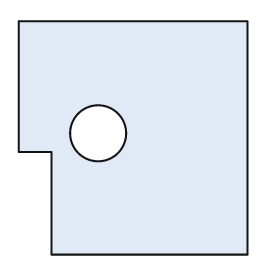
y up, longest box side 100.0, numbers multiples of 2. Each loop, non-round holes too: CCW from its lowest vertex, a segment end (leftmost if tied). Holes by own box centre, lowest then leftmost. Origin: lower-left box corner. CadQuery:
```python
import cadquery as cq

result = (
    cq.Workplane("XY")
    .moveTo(14.0, 0.0)
    .lineTo(98.0, 0.0)
    .lineTo(98.0, 100.0)
    .lineTo(0.0, 100.0)
    .lineTo(0.0, 44.0)
    .lineTo(14.0, 44.0)
    .close()
    .moveTo(34.0, 52.0)
    .circle(12.0)
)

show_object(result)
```